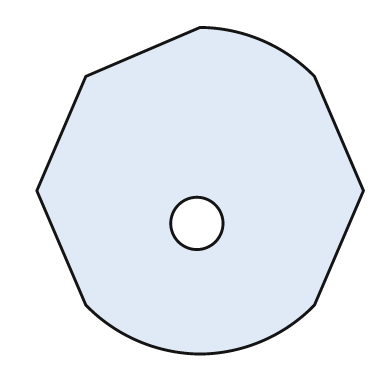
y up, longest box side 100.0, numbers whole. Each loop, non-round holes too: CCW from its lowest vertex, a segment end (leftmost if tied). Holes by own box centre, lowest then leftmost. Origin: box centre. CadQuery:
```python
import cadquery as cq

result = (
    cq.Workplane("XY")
    .moveTo(0.0, -50.0)
    .threePointArc((19.0, -46.0), (35.0, -35.0))
    .lineTo(50.0, 0.0)
    .lineTo(35.0, 35.0)
    .threePointArc((19.0, 46.0), (0.0, 50.0))
    .lineTo(-35.0, 35.0)
    .lineTo(-50.0, 0.0)
    .lineTo(-35.0, -35.0)
    .threePointArc((-19.0, -46.0), (0.0, -50.0))
    .close()
    .moveTo(-1.0, -10.0)
    .circle(8.0)
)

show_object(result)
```